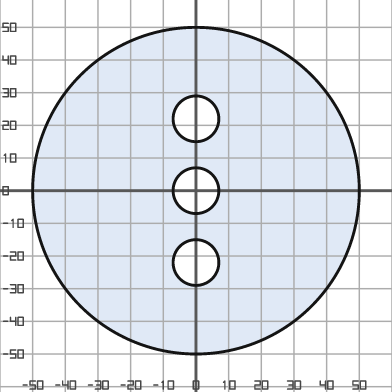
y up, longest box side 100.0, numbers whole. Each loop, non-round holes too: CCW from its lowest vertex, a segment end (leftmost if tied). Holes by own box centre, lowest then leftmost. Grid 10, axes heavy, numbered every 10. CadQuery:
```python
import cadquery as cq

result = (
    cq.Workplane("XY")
    .moveTo(0.0, 0.0)
    .circle(50.0)
    .moveTo(0.0, -22.0)
    .circle(7.0)
    .moveTo(0.0, 0.0)
    .circle(7.0)
    .moveTo(0.0, 22.0)
    .circle(7.0)
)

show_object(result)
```